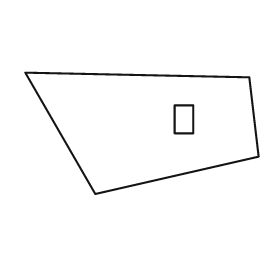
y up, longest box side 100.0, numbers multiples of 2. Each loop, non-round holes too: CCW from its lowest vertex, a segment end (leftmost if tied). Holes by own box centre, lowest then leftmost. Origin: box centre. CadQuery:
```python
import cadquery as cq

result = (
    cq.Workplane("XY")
    .moveTo(-20.0, -26.0)
    .lineTo(50.0, -10.0)
    .lineTo(46.0, 24.0)
    .lineTo(-50.0, 26.0)
    .close()
    .moveTo(14.0, 0.0)
    .lineTo(22.0, 0.0)
    .lineTo(22.0, 12.0)
    .lineTo(14.0, 12.0)
    .close()
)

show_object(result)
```